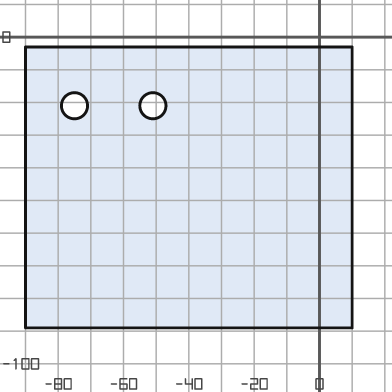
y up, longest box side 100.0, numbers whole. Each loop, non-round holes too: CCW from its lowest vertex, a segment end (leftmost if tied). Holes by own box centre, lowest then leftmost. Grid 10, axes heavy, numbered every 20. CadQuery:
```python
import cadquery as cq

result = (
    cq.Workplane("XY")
    .moveTo(-90.0, -89.0)
    .lineTo(10.0, -89.0)
    .lineTo(10.0, -3.0)
    .lineTo(-90.0, -3.0)
    .close()
    .moveTo(-75.0, -21.0)
    .circle(4.0)
    .moveTo(-51.0, -21.0)
    .circle(4.0)
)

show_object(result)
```